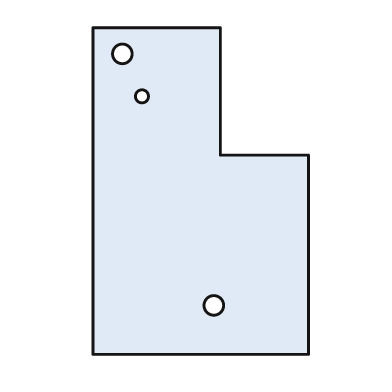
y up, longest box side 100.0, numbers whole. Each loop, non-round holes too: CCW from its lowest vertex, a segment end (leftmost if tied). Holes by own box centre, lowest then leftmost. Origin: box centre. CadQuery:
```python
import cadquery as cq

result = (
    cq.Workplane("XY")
    .moveTo(-33.0, -50.0)
    .lineTo(33.0, -50.0)
    .lineTo(33.0, 11.0)
    .lineTo(6.0, 11.0)
    .lineTo(6.0, 50.0)
    .lineTo(-33.0, 50.0)
    .close()
    .moveTo(4.0, -35.0)
    .circle(3.0)
    .moveTo(-18.0, 29.0)
    .circle(2.0)
    .moveTo(-24.0, 42.0)
    .circle(3.0)
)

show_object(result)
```